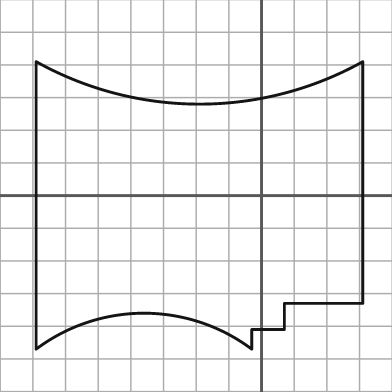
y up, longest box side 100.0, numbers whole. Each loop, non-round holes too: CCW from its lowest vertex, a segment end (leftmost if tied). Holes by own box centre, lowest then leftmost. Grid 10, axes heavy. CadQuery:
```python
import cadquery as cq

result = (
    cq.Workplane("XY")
    .moveTo(-69.0, -47.0)
    .threePointArc((-36.0, -36.0), (-3.0, -47.0))
    .lineTo(-3.0, -41.0)
    .lineTo(7.0, -41.0)
    .lineTo(7.0, -33.0)
    .lineTo(31.0, -33.0)
    .lineTo(31.0, 41.0)
    .threePointArc((-19.0, 28.0), (-69.0, 41.0))
    .close()
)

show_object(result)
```